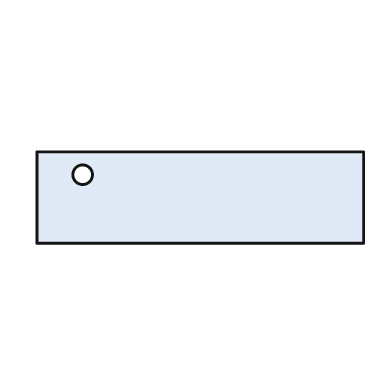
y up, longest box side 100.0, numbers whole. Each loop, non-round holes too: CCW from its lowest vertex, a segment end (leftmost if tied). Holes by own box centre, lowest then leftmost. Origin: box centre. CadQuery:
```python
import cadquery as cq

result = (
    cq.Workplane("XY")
    .moveTo(-50.0, -14.0)
    .lineTo(50.0, -14.0)
    .lineTo(50.0, 14.0)
    .lineTo(-50.0, 14.0)
    .close()
    .moveTo(-36.0, 7.0)
    .circle(3.0)
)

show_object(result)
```